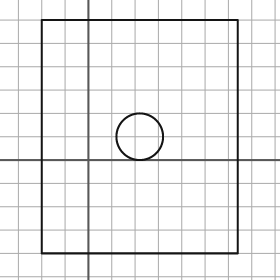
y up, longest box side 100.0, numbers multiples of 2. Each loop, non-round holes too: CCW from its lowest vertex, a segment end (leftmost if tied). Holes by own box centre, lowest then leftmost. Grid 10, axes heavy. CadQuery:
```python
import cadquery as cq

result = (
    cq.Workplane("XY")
    .moveTo(-20.0, -40.0)
    .lineTo(64.0, -40.0)
    .lineTo(64.0, 60.0)
    .lineTo(-20.0, 60.0)
    .close()
    .moveTo(22.0, 10.0)
    .circle(10.0)
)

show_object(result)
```